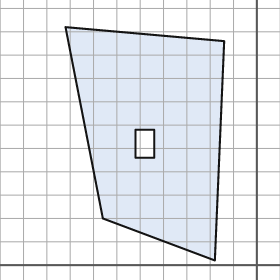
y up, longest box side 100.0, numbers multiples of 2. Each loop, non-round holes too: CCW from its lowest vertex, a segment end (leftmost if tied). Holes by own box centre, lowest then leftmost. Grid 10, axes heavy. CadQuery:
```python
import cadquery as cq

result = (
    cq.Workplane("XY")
    .moveTo(-18.0, 2.0)
    .lineTo(-14.0, 96.0)
    .lineTo(-82.0, 102.0)
    .lineTo(-66.0, 20.0)
    .close()
    .moveTo(-52.0, 46.0)
    .lineTo(-44.0, 46.0)
    .lineTo(-44.0, 58.0)
    .lineTo(-52.0, 58.0)
    .close()
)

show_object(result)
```